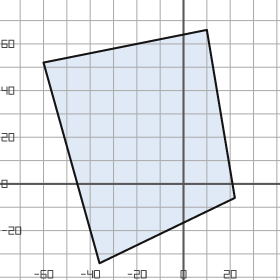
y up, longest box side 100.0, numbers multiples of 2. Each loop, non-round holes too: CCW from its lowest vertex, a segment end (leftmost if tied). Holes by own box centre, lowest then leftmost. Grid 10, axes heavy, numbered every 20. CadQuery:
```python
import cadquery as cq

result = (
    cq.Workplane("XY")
    .moveTo(-36.0, -34.0)
    .lineTo(22.0, -6.0)
    .lineTo(10.0, 66.0)
    .lineTo(-60.0, 52.0)
    .close()
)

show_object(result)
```